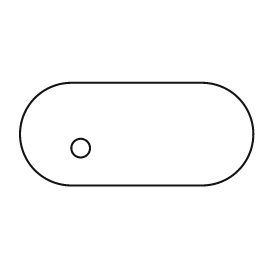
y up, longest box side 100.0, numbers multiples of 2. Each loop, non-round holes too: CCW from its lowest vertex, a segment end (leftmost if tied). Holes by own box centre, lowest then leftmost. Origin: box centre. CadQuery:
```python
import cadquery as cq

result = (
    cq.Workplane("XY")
    .moveTo(-28.0, -22.0)
    .lineTo(28.0, -22.0)
    .threePointArc((50.0, 0.0), (28.0, 22.0))
    .lineTo(-28.0, 22.0)
    .threePointArc((-50.0, 0.0), (-28.0, -22.0))
    .close()
    .moveTo(-24.0, -6.0)
    .circle(4.0)
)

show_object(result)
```